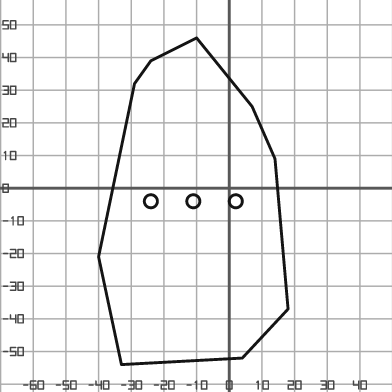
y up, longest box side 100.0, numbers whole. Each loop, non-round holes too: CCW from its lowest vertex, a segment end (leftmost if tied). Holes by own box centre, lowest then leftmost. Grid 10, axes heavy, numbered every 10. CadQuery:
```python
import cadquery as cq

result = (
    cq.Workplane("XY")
    .moveTo(-33.0, -54.0)
    .lineTo(4.0, -52.0)
    .lineTo(18.0, -37.0)
    .lineTo(14.0, 9.0)
    .lineTo(7.0, 25.0)
    .lineTo(-10.0, 46.0)
    .lineTo(-24.0, 39.0)
    .lineTo(-29.0, 32.0)
    .lineTo(-40.0, -21.0)
    .close()
    .moveTo(-24.0, -4.0)
    .circle(2.0)
    .moveTo(-11.0, -4.0)
    .circle(2.0)
    .moveTo(2.0, -4.0)
    .circle(2.0)
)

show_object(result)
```